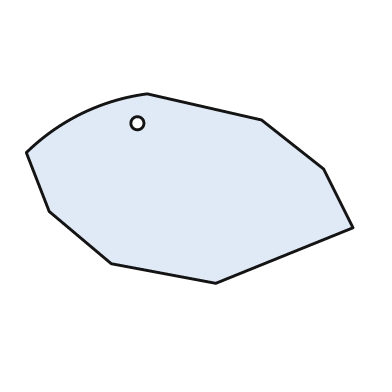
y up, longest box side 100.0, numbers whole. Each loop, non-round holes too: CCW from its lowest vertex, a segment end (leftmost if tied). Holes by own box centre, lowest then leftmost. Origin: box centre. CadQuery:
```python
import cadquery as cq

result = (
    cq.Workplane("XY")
    .moveTo(8.0, -29.0)
    .lineTo(50.0, -12.0)
    .lineTo(41.0, 6.0)
    .lineTo(22.0, 21.0)
    .lineTo(-13.0, 29.0)
    .threePointArc((-33.0, 23.0), (-50.0, 11.0))
    .lineTo(-43.0, -7.0)
    .lineTo(-24.0, -23.0)
    .close()
    .moveTo(-16.0, 20.0)
    .circle(2.0)
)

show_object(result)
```